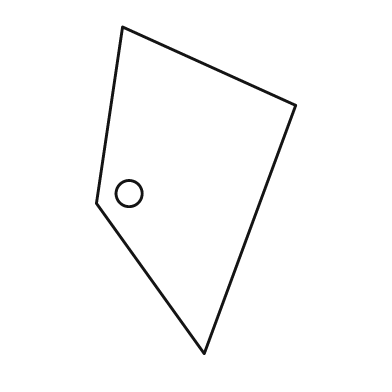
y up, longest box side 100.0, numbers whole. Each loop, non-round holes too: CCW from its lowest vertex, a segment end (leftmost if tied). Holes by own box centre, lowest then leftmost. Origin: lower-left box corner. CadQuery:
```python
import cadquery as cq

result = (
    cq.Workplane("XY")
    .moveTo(33.0, 0.0)
    .lineTo(61.0, 76.0)
    .lineTo(8.0, 100.0)
    .lineTo(0.0, 46.0)
    .close()
    .moveTo(10.0, 49.0)
    .circle(4.0)
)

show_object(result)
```